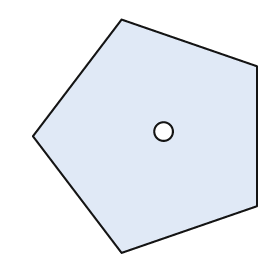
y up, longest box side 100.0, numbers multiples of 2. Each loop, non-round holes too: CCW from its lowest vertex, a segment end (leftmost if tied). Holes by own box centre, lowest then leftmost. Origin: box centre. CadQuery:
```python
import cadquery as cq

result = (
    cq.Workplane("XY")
    .moveTo(-10.0, -50.0)
    .lineTo(48.0, -30.0)
    .lineTo(48.0, 30.0)
    .lineTo(-10.0, 50.0)
    .lineTo(-48.0, 0.0)
    .close()
    .moveTo(8.0, 2.0)
    .circle(4.0)
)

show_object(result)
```